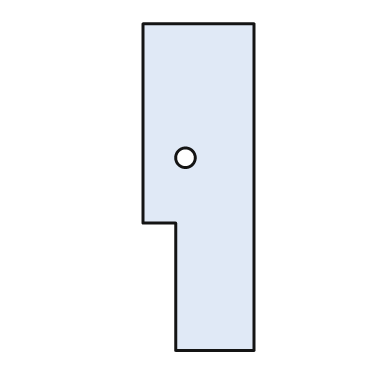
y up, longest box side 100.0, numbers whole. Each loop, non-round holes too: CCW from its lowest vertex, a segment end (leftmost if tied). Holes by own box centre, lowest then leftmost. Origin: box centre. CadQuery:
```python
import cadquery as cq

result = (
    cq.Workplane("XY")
    .moveTo(-7.0, -50.0)
    .lineTo(17.0, -50.0)
    .lineTo(17.0, 50.0)
    .lineTo(-17.0, 50.0)
    .lineTo(-17.0, -11.0)
    .lineTo(-7.0, -11.0)
    .close()
    .moveTo(-4.0, 9.0)
    .circle(3.0)
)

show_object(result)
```